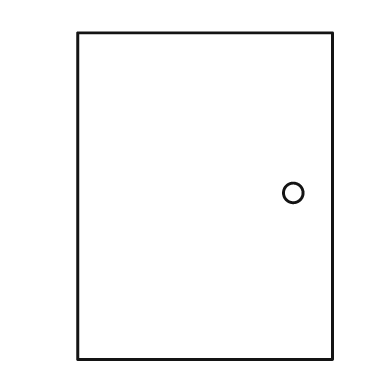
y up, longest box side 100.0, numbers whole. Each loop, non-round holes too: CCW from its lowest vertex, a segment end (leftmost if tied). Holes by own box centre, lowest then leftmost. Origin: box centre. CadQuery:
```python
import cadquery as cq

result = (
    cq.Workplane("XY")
    .moveTo(-39.0, -50.0)
    .lineTo(39.0, -50.0)
    .lineTo(39.0, 50.0)
    .lineTo(-39.0, 50.0)
    .close()
    .moveTo(27.0, 1.0)
    .circle(3.0)
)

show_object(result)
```